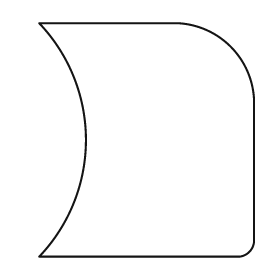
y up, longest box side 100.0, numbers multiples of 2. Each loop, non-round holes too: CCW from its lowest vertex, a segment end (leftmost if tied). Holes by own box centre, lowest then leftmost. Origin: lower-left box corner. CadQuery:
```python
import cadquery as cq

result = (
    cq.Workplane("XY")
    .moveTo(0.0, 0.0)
    .lineTo(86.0, 0.0)
    .threePointArc((90.0, 2.0), (92.0, 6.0))
    .lineTo(92.0, 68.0)
    .threePointArc((82.0, 90.0), (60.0, 100.0))
    .lineTo(0.0, 100.0)
    .threePointArc((20.0, 50.0), (0.0, 0.0))
    .close()
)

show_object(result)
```